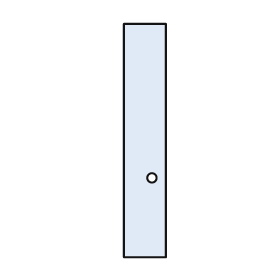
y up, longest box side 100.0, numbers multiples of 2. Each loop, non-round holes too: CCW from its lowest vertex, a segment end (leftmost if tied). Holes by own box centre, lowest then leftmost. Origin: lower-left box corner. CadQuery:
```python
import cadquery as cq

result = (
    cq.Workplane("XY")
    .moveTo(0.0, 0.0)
    .lineTo(18.0, 0.0)
    .lineTo(18.0, 100.0)
    .lineTo(0.0, 100.0)
    .close()
    .moveTo(12.0, 34.0)
    .circle(2.0)
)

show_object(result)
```